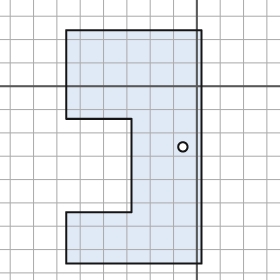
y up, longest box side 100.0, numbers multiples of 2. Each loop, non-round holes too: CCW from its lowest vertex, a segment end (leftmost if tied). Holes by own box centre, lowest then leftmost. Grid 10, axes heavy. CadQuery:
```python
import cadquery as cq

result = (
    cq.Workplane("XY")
    .moveTo(-56.0, -76.0)
    .lineTo(2.0, -76.0)
    .lineTo(2.0, 24.0)
    .lineTo(-56.0, 24.0)
    .lineTo(-56.0, -14.0)
    .lineTo(-28.0, -14.0)
    .lineTo(-28.0, -54.0)
    .lineTo(-56.0, -54.0)
    .close()
    .moveTo(-6.0, -26.0)
    .circle(2.0)
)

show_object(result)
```